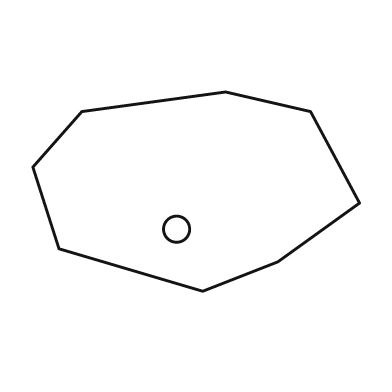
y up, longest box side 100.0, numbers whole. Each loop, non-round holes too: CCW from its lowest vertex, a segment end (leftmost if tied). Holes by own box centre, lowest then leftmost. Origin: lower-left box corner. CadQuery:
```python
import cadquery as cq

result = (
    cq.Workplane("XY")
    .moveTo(52.0, 0.0)
    .lineTo(75.0, 9.0)
    .lineTo(100.0, 27.0)
    .lineTo(85.0, 55.0)
    .lineTo(59.0, 61.0)
    .lineTo(15.0, 55.0)
    .lineTo(0.0, 38.0)
    .lineTo(8.0, 13.0)
    .close()
    .moveTo(44.0, 19.0)
    .circle(4.0)
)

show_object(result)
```